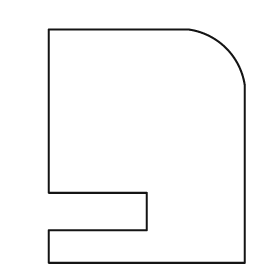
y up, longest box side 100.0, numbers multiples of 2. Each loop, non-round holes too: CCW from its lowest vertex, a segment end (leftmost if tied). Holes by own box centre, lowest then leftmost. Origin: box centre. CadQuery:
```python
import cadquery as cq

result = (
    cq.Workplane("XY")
    .moveTo(-42.0, -50.0)
    .lineTo(42.0, -50.0)
    .lineTo(42.0, 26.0)
    .threePointArc((34.0, 42.0), (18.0, 50.0))
    .lineTo(-42.0, 50.0)
    .lineTo(-42.0, -20.0)
    .lineTo(0.0, -20.0)
    .lineTo(0.0, -36.0)
    .lineTo(-42.0, -36.0)
    .close()
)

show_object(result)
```